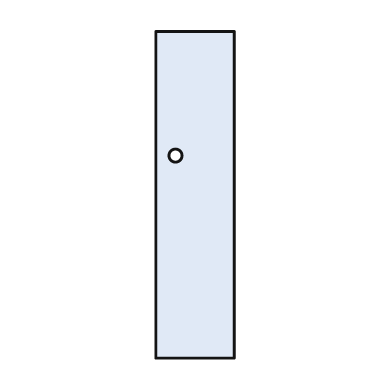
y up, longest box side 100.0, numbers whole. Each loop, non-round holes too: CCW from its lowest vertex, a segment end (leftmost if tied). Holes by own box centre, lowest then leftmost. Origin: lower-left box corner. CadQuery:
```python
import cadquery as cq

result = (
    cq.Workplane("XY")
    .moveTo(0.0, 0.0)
    .lineTo(24.0, 0.0)
    .lineTo(24.0, 100.0)
    .lineTo(0.0, 100.0)
    .close()
    .moveTo(6.0, 62.0)
    .circle(2.0)
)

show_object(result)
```